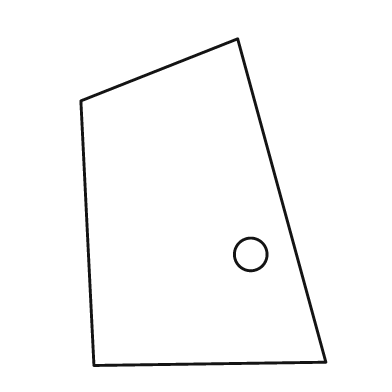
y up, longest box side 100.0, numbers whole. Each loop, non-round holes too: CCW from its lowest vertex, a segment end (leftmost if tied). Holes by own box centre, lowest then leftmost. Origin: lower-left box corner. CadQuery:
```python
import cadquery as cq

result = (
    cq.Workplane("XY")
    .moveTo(4.0, 0.0)
    .lineTo(75.0, 1.0)
    .lineTo(48.0, 100.0)
    .lineTo(0.0, 81.0)
    .close()
    .moveTo(52.0, 34.0)
    .circle(5.0)
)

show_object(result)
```